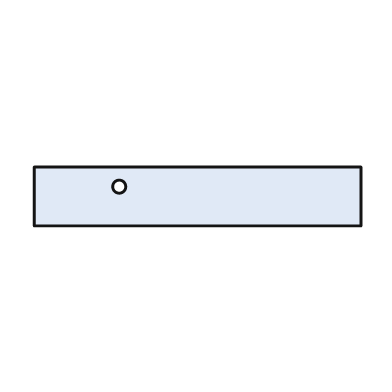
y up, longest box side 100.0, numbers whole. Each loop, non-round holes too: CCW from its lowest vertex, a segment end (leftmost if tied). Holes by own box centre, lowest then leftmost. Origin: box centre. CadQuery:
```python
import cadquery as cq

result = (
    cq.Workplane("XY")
    .moveTo(-50.0, -9.0)
    .lineTo(50.0, -9.0)
    .lineTo(50.0, 9.0)
    .lineTo(-50.0, 9.0)
    .close()
    .moveTo(-24.0, 3.0)
    .circle(2.0)
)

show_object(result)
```